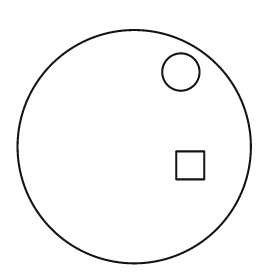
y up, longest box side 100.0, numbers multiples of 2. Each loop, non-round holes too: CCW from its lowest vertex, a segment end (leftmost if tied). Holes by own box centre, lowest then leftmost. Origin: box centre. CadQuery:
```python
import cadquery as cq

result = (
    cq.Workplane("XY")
    .moveTo(0.0, 0.0)
    .circle(50.0)
    .moveTo(18.0, -14.0)
    .lineTo(30.0, -14.0)
    .lineTo(30.0, -2.0)
    .lineTo(18.0, -2.0)
    .close()
    .moveTo(20.0, 32.0)
    .circle(8.0)
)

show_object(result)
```